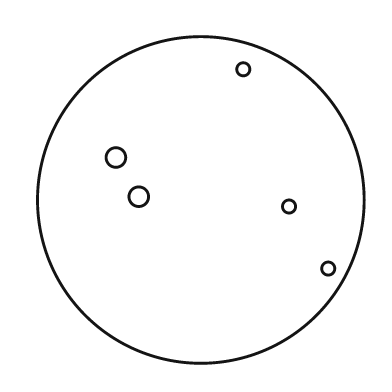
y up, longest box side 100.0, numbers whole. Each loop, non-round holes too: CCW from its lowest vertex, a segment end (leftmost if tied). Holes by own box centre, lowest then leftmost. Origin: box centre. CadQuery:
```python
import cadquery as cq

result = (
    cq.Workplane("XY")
    .moveTo(0.0, 0.0)
    .circle(50.0)
    .moveTo(39.0, -21.0)
    .circle(2.0)
    .moveTo(27.0, -2.0)
    .circle(2.0)
    .moveTo(-19.0, 1.0)
    .circle(3.0)
    .moveTo(-26.0, 13.0)
    .circle(3.0)
    .moveTo(13.0, 40.0)
    .circle(2.0)
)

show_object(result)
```